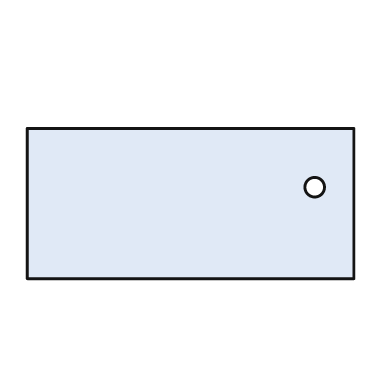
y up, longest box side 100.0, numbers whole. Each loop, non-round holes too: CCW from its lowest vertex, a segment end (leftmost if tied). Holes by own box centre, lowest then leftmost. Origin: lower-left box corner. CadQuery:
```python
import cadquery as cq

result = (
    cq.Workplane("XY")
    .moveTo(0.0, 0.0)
    .lineTo(100.0, 0.0)
    .lineTo(100.0, 46.0)
    .lineTo(0.0, 46.0)
    .close()
    .moveTo(88.0, 28.0)
    .circle(3.0)
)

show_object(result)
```